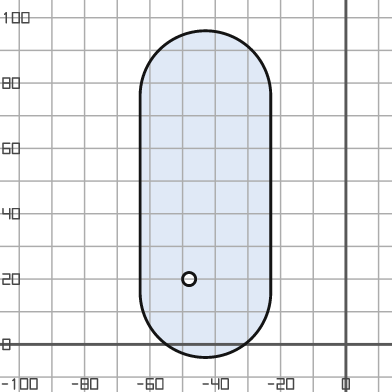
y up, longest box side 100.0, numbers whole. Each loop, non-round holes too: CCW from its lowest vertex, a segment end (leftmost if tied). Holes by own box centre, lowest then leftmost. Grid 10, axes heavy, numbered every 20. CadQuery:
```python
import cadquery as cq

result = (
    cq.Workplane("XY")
    .moveTo(-63.0, 16.0)
    .threePointArc((-43.0, -4.0), (-23.0, 16.0))
    .lineTo(-23.0, 76.0)
    .threePointArc((-43.0, 96.0), (-63.0, 76.0))
    .close()
    .moveTo(-48.0, 20.0)
    .circle(2.0)
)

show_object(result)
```